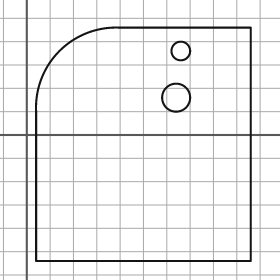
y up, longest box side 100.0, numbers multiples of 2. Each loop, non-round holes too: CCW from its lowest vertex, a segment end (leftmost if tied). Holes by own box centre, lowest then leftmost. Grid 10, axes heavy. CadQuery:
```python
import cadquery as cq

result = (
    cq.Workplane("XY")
    .moveTo(4.0, -54.0)
    .lineTo(96.0, -54.0)
    .lineTo(96.0, 46.0)
    .lineTo(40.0, 46.0)
    .threePointArc((14.0, 36.0), (4.0, 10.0))
    .close()
    .moveTo(64.0, 16.0)
    .circle(6.0)
    .moveTo(66.0, 36.0)
    .circle(4.0)
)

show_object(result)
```